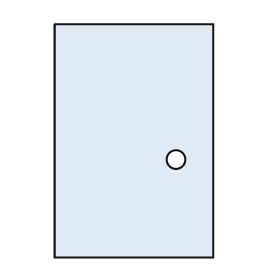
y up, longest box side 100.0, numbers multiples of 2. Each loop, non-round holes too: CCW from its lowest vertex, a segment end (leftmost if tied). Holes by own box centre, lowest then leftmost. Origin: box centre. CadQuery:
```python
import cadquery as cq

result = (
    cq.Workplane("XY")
    .moveTo(-34.0, -50.0)
    .lineTo(34.0, -50.0)
    .lineTo(34.0, 50.0)
    .lineTo(-34.0, 50.0)
    .close()
    .moveTo(18.0, -8.0)
    .circle(4.0)
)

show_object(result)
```